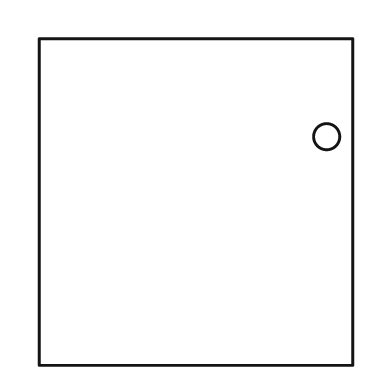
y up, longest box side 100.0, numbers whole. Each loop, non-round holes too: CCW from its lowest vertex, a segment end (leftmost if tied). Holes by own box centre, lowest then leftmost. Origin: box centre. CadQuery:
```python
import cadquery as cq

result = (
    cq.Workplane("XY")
    .moveTo(-48.0, -50.0)
    .lineTo(48.0, -50.0)
    .lineTo(48.0, 50.0)
    .lineTo(-48.0, 50.0)
    .close()
    .moveTo(40.0, 20.0)
    .circle(4.0)
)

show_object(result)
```